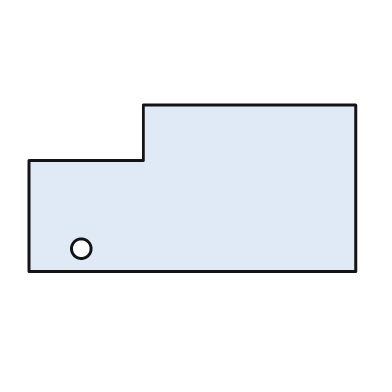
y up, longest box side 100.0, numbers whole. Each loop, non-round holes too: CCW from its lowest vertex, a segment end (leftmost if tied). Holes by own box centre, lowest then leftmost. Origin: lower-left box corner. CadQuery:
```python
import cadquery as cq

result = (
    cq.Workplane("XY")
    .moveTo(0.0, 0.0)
    .lineTo(100.0, 0.0)
    .lineTo(100.0, 51.0)
    .lineTo(35.0, 51.0)
    .lineTo(35.0, 34.0)
    .lineTo(0.0, 34.0)
    .close()
    .moveTo(16.0, 7.0)
    .circle(3.0)
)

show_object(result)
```